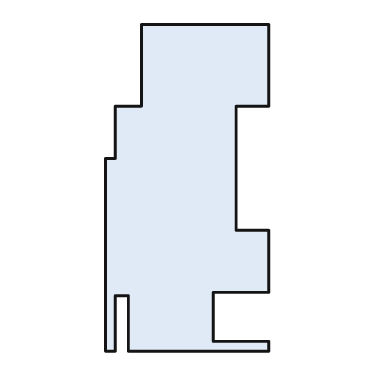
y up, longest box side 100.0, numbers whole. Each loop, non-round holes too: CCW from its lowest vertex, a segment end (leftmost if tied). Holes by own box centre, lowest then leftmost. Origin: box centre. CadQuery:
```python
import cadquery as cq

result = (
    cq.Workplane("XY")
    .moveTo(-25.0, -50.0)
    .lineTo(-22.0, -50.0)
    .lineTo(-22.0, -33.0)
    .lineTo(-18.0, -33.0)
    .lineTo(-18.0, -50.0)
    .lineTo(25.0, -50.0)
    .lineTo(25.0, -47.0)
    .lineTo(8.0, -47.0)
    .lineTo(8.0, -32.0)
    .lineTo(25.0, -32.0)
    .lineTo(25.0, -13.0)
    .lineTo(15.0, -13.0)
    .lineTo(15.0, 25.0)
    .lineTo(25.0, 25.0)
    .lineTo(25.0, 50.0)
    .lineTo(-14.0, 50.0)
    .lineTo(-14.0, 25.0)
    .lineTo(-22.0, 25.0)
    .lineTo(-22.0, 9.0)
    .lineTo(-25.0, 9.0)
    .close()
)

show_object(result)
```